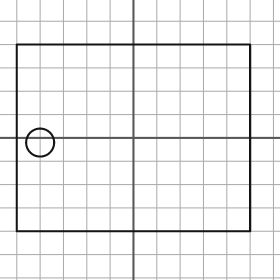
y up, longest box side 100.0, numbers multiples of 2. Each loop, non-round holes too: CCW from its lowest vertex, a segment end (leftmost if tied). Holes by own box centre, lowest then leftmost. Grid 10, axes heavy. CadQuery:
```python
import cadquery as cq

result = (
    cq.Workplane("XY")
    .moveTo(-50.0, -40.0)
    .lineTo(50.0, -40.0)
    .lineTo(50.0, 40.0)
    .lineTo(-50.0, 40.0)
    .close()
    .moveTo(-40.0, -2.0)
    .circle(6.0)
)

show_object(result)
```